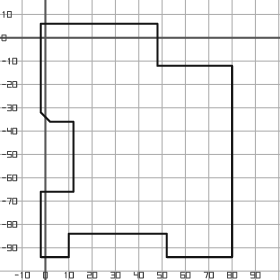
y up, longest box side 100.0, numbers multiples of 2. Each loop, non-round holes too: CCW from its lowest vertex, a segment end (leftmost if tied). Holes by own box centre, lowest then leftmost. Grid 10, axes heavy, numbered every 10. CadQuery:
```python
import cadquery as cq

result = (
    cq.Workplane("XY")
    .moveTo(-2.0, -94.0)
    .lineTo(10.0, -94.0)
    .lineTo(10.0, -84.0)
    .lineTo(52.0, -84.0)
    .lineTo(52.0, -94.0)
    .lineTo(80.0, -94.0)
    .lineTo(80.0, -12.0)
    .lineTo(48.0, -12.0)
    .lineTo(48.0, 6.0)
    .lineTo(-2.0, 6.0)
    .lineTo(-2.0, -32.0)
    .lineTo(2.0, -36.0)
    .lineTo(12.0, -36.0)
    .lineTo(12.0, -66.0)
    .lineTo(-2.0, -66.0)
    .close()
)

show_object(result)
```